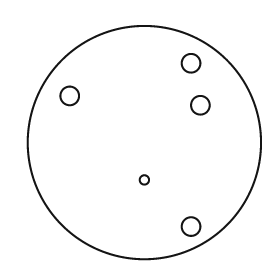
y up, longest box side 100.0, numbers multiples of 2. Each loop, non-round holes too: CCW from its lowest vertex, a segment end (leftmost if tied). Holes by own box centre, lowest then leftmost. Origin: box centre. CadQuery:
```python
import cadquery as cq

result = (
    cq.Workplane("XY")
    .moveTo(0.0, 0.0)
    .circle(50.0)
    .moveTo(20.0, -36.0)
    .circle(4.0)
    .moveTo(0.0, -16.0)
    .circle(2.0)
    .moveTo(24.0, 16.0)
    .circle(4.0)
    .moveTo(-32.0, 20.0)
    .circle(4.0)
    .moveTo(20.0, 34.0)
    .circle(4.0)
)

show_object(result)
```